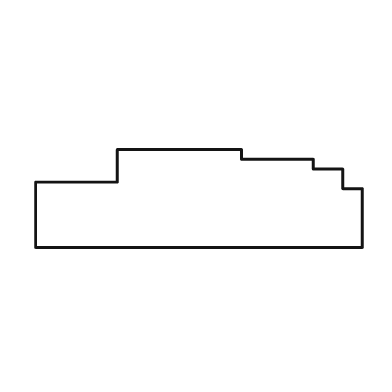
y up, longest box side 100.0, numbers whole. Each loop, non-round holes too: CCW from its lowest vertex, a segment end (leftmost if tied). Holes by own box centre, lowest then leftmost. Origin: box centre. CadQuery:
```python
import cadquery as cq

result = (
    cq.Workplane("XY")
    .moveTo(-50.0, -15.0)
    .lineTo(50.0, -15.0)
    .lineTo(50.0, 3.0)
    .lineTo(44.0, 3.0)
    .lineTo(44.0, 9.0)
    .lineTo(35.0, 9.0)
    .lineTo(35.0, 12.0)
    .lineTo(13.0, 12.0)
    .lineTo(13.0, 15.0)
    .lineTo(-25.0, 15.0)
    .lineTo(-25.0, 5.0)
    .lineTo(-50.0, 5.0)
    .close()
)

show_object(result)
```